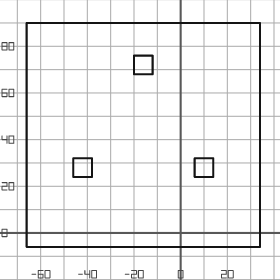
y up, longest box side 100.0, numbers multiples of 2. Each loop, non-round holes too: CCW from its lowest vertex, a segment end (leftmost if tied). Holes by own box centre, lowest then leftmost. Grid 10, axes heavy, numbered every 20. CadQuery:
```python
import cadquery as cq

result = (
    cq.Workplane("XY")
    .moveTo(-66.0, -6.0)
    .lineTo(34.0, -6.0)
    .lineTo(34.0, 90.0)
    .lineTo(-66.0, 90.0)
    .close()
    .moveTo(-46.0, 24.0)
    .lineTo(-38.0, 24.0)
    .lineTo(-38.0, 32.0)
    .lineTo(-46.0, 32.0)
    .close()
    .moveTo(6.0, 24.0)
    .lineTo(14.0, 24.0)
    .lineTo(14.0, 32.0)
    .lineTo(6.0, 32.0)
    .close()
    .moveTo(-20.0, 68.0)
    .lineTo(-12.0, 68.0)
    .lineTo(-12.0, 76.0)
    .lineTo(-20.0, 76.0)
    .close()
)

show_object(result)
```